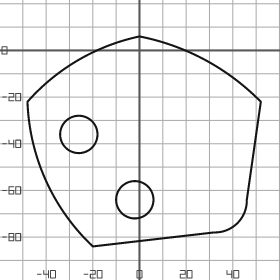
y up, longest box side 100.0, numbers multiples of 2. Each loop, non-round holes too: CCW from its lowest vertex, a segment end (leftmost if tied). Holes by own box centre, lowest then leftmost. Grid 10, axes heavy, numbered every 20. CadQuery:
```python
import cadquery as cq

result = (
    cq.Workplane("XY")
    .moveTo(-20.0, -84.0)
    .lineTo(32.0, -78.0)
    .threePointArc((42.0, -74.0), (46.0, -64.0))
    .lineTo(52.0, -22.0)
    .threePointArc((28.0, -4.0), (0.0, 6.0))
    .threePointArc((-26.0, -4.0), (-48.0, -22.0))
    .threePointArc((-40.0, -56.0), (-20.0, -84.0))
    .close()
    .moveTo(-2.0, -64.0)
    .circle(8.0)
    .moveTo(-26.0, -36.0)
    .circle(8.0)
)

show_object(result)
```